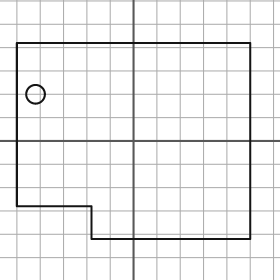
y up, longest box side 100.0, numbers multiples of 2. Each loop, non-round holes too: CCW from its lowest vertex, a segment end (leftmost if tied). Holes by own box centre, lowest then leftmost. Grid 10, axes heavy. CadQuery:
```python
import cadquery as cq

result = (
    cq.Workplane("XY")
    .moveTo(-18.0, -42.0)
    .lineTo(50.0, -42.0)
    .lineTo(50.0, 42.0)
    .lineTo(-50.0, 42.0)
    .lineTo(-50.0, -28.0)
    .lineTo(-18.0, -28.0)
    .close()
    .moveTo(-42.0, 20.0)
    .circle(4.0)
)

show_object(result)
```